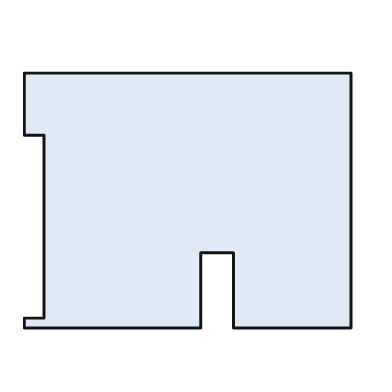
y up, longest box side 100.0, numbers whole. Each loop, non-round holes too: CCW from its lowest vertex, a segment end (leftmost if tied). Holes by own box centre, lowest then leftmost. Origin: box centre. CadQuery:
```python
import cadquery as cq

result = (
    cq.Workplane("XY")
    .moveTo(-50.0, -39.0)
    .lineTo(4.0, -39.0)
    .lineTo(4.0, -16.0)
    .lineTo(14.0, -16.0)
    .lineTo(14.0, -39.0)
    .lineTo(50.0, -39.0)
    .lineTo(50.0, 39.0)
    .lineTo(-50.0, 39.0)
    .lineTo(-50.0, 20.0)
    .lineTo(-44.0, 20.0)
    .lineTo(-44.0, -36.0)
    .lineTo(-50.0, -36.0)
    .close()
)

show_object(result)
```